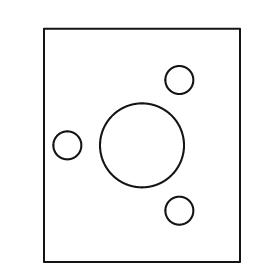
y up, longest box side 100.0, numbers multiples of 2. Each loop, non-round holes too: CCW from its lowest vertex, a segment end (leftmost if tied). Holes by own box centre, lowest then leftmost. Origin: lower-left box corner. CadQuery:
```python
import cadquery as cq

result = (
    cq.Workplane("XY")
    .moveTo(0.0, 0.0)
    .lineTo(84.0, 0.0)
    .lineTo(84.0, 100.0)
    .lineTo(0.0, 100.0)
    .close()
    .moveTo(58.0, 22.0)
    .circle(6.0)
    .moveTo(10.0, 50.0)
    .circle(6.0)
    .moveTo(42.0, 50.0)
    .circle(18.0)
    .moveTo(58.0, 78.0)
    .circle(6.0)
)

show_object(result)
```